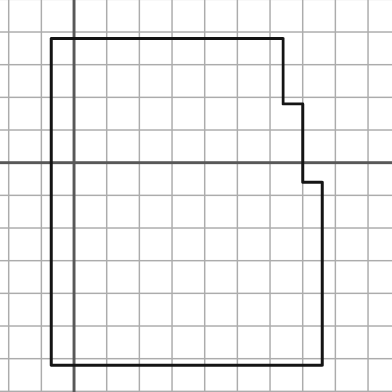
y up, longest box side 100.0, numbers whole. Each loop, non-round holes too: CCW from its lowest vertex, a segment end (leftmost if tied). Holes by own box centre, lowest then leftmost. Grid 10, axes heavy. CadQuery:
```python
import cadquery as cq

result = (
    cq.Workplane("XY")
    .moveTo(-7.0, -62.0)
    .lineTo(76.0, -62.0)
    .lineTo(76.0, -6.0)
    .lineTo(70.0, -6.0)
    .lineTo(70.0, 18.0)
    .lineTo(64.0, 18.0)
    .lineTo(64.0, 38.0)
    .lineTo(-7.0, 38.0)
    .close()
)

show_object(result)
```